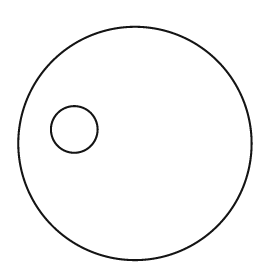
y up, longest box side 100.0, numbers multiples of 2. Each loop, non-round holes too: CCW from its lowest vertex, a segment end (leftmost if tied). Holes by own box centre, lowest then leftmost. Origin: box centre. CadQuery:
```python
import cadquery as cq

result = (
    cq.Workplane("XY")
    .moveTo(0.0, 0.0)
    .circle(50.0)
    .moveTo(-26.0, 6.0)
    .circle(10.0)
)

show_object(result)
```